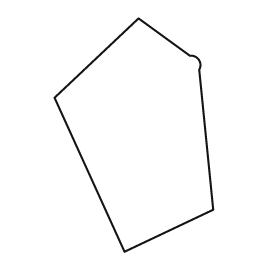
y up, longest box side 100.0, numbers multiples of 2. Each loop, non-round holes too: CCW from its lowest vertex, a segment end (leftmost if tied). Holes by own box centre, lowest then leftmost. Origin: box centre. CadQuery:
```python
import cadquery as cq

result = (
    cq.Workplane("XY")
    .moveTo(-4.0, -50.0)
    .lineTo(34.0, -32.0)
    .lineTo(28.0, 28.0)
    .threePointArc((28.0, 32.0), (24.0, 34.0))
    .lineTo(2.0, 50.0)
    .lineTo(-34.0, 16.0)
    .close()
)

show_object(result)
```